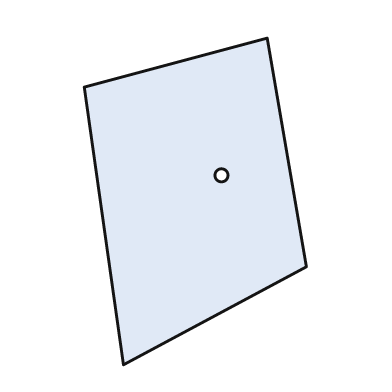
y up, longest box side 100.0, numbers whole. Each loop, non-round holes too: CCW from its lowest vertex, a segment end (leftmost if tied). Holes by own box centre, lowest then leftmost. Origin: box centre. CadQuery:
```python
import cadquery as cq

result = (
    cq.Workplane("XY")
    .moveTo(-22.0, -50.0)
    .lineTo(34.0, -20.0)
    .lineTo(22.0, 50.0)
    .lineTo(-34.0, 35.0)
    .close()
    .moveTo(8.0, 8.0)
    .circle(2.0)
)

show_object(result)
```